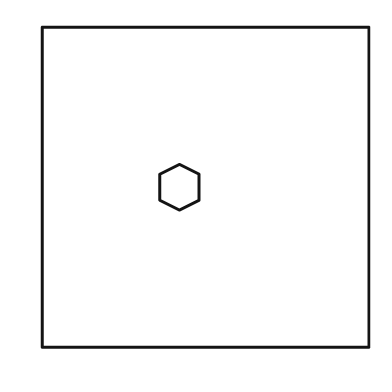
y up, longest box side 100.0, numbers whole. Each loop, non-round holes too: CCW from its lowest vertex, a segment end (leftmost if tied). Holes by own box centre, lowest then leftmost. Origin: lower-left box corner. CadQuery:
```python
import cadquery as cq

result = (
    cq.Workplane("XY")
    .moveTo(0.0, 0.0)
    .lineTo(100.0, 0.0)
    .lineTo(100.0, 98.0)
    .lineTo(0.0, 98.0)
    .close()
    .moveTo(42.0, 42.0)
    .lineTo(48.0, 45.0)
    .lineTo(48.0, 53.0)
    .lineTo(42.0, 56.0)
    .lineTo(36.0, 53.0)
    .lineTo(36.0, 45.0)
    .close()
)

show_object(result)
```